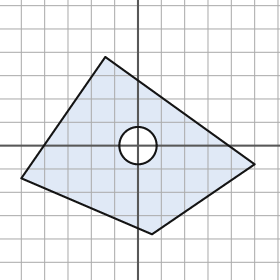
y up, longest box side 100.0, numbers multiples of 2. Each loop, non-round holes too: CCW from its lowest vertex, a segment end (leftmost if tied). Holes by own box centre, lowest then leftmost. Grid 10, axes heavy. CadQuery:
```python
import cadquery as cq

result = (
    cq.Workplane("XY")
    .moveTo(6.0, -38.0)
    .lineTo(50.0, -8.0)
    .lineTo(-14.0, 38.0)
    .lineTo(-50.0, -14.0)
    .close()
    .moveTo(0.0, 0.0)
    .circle(8.0)
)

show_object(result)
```